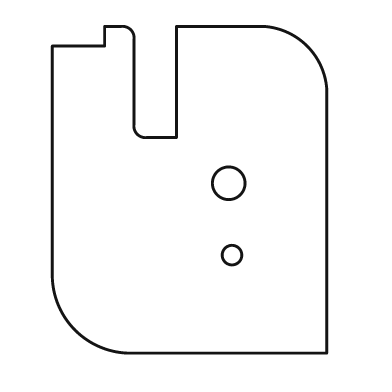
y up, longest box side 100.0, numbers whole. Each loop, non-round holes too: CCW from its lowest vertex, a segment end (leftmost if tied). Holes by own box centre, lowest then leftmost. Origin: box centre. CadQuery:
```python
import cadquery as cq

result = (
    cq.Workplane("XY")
    .moveTo(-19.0, -50.0)
    .lineTo(42.0, -50.0)
    .lineTo(42.0, 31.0)
    .threePointArc((36.0, 44.0), (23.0, 50.0))
    .lineTo(-4.0, 50.0)
    .lineTo(-4.0, 16.0)
    .lineTo(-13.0, 16.0)
    .threePointArc((-16.0, 17.0), (-17.0, 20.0))
    .lineTo(-17.0, 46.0)
    .threePointArc((-18.0, 49.0), (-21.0, 50.0))
    .lineTo(-26.0, 50.0)
    .lineTo(-26.0, 44.0)
    .lineTo(-42.0, 44.0)
    .lineTo(-42.0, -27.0)
    .threePointArc((-35.0, -43.0), (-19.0, -50.0))
    .close()
    .moveTo(13.0, -20.0)
    .circle(3.0)
    .moveTo(12.0, 2.0)
    .circle(5.0)
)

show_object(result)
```